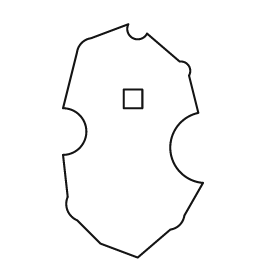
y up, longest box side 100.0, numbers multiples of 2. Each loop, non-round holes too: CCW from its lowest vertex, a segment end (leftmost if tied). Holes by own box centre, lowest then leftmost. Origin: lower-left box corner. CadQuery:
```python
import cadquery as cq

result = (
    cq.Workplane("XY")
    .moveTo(32.0, 0.0)
    .lineTo(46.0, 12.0)
    .threePointArc((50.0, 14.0), (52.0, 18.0))
    .lineTo(60.0, 32.0)
    .threePointArc((46.0, 46.0), (58.0, 62.0))
    .lineTo(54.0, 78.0)
    .threePointArc((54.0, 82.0), (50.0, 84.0))
    .lineTo(36.0, 96.0)
    .threePointArc((30.0, 94.0), (28.0, 100.0))
    .lineTo(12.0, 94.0)
    .threePointArc((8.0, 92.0), (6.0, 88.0))
    .lineTo(0.0, 64.0)
    .threePointArc((10.0, 54.0), (0.0, 44.0))
    .lineTo(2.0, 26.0)
    .threePointArc((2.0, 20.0), (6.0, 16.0))
    .lineTo(16.0, 6.0)
    .close()
    .moveTo(26.0, 64.0)
    .lineTo(34.0, 64.0)
    .lineTo(34.0, 72.0)
    .lineTo(26.0, 72.0)
    .close()
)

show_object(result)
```